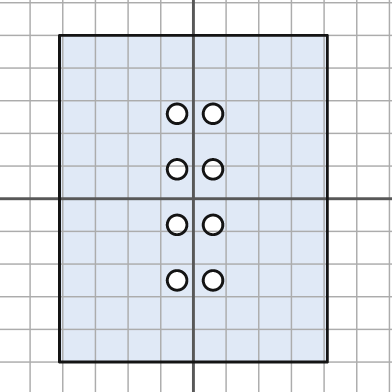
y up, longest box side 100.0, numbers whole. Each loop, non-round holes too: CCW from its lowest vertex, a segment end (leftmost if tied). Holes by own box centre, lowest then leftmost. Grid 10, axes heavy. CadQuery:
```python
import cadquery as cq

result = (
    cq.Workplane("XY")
    .moveTo(-41.0, -50.0)
    .lineTo(41.0, -50.0)
    .lineTo(41.0, 50.0)
    .lineTo(-41.0, 50.0)
    .close()
    .moveTo(-5.0, -25.0)
    .circle(3.0)
    .moveTo(6.0, -25.0)
    .circle(3.0)
    .moveTo(-5.0, -8.0)
    .circle(3.0)
    .moveTo(6.0, -8.0)
    .circle(3.0)
    .moveTo(-5.0, 9.0)
    .circle(3.0)
    .moveTo(6.0, 9.0)
    .circle(3.0)
    .moveTo(-5.0, 26.0)
    .circle(3.0)
    .moveTo(6.0, 26.0)
    .circle(3.0)
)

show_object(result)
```